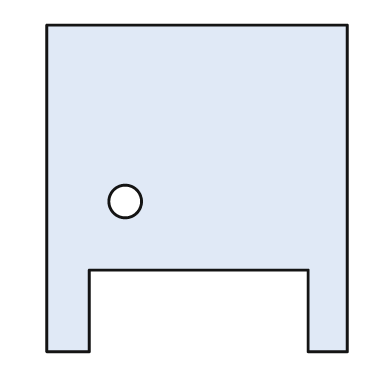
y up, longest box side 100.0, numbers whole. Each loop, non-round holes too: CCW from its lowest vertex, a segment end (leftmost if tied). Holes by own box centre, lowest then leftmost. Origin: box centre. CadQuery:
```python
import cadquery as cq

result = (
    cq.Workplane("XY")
    .moveTo(-46.0, -50.0)
    .lineTo(-33.0, -50.0)
    .lineTo(-33.0, -25.0)
    .lineTo(34.0, -25.0)
    .lineTo(34.0, -50.0)
    .lineTo(46.0, -50.0)
    .lineTo(46.0, 50.0)
    .lineTo(-46.0, 50.0)
    .close()
    .moveTo(-22.0, -4.0)
    .circle(5.0)
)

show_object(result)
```